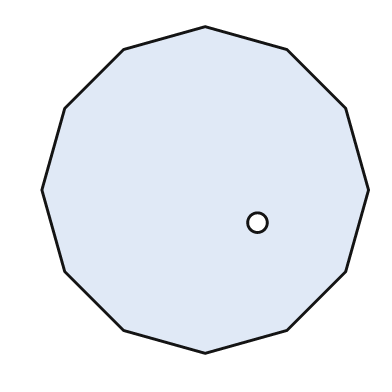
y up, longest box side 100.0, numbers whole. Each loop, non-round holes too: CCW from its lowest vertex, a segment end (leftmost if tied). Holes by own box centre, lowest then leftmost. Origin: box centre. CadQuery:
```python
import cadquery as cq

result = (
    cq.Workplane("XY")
    .moveTo(0.0, -50.0)
    .lineTo(25.0, -43.0)
    .lineTo(43.0, -25.0)
    .lineTo(50.0, 0.0)
    .lineTo(43.0, 25.0)
    .lineTo(25.0, 43.0)
    .lineTo(0.0, 50.0)
    .lineTo(-25.0, 43.0)
    .lineTo(-43.0, 25.0)
    .lineTo(-50.0, 0.0)
    .lineTo(-43.0, -25.0)
    .lineTo(-25.0, -43.0)
    .close()
    .moveTo(16.0, -10.0)
    .circle(3.0)
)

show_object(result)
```